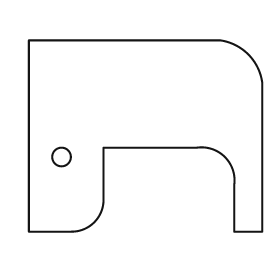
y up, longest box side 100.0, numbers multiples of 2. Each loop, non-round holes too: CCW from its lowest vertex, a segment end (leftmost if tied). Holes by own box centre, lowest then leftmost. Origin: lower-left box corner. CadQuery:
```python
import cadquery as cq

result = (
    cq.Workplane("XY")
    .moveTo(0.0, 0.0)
    .lineTo(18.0, 0.0)
    .threePointArc((28.0, 4.0), (32.0, 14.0))
    .lineTo(32.0, 36.0)
    .lineTo(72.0, 36.0)
    .threePointArc((84.0, 32.0), (88.0, 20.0))
    .lineTo(88.0, 0.0)
    .lineTo(100.0, 0.0)
    .lineTo(100.0, 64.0)
    .threePointArc((94.0, 76.0), (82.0, 82.0))
    .lineTo(0.0, 82.0)
    .close()
    .moveTo(14.0, 32.0)
    .circle(4.0)
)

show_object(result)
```